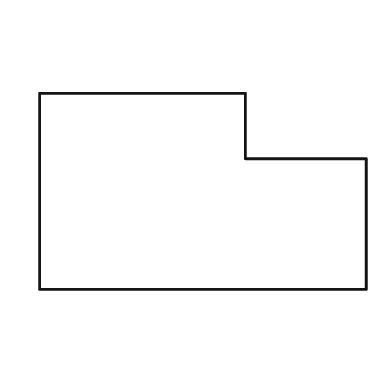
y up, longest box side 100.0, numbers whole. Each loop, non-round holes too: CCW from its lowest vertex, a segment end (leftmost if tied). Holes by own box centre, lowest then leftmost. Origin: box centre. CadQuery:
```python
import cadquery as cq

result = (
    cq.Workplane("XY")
    .moveTo(-50.0, -30.0)
    .lineTo(50.0, -30.0)
    .lineTo(50.0, 10.0)
    .lineTo(13.0, 10.0)
    .lineTo(13.0, 30.0)
    .lineTo(-50.0, 30.0)
    .close()
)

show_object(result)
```